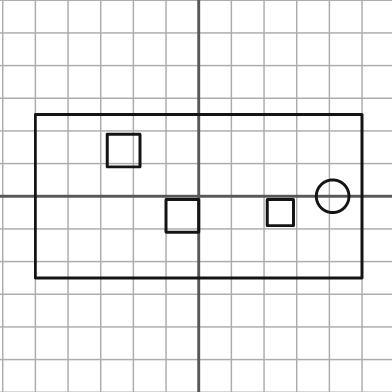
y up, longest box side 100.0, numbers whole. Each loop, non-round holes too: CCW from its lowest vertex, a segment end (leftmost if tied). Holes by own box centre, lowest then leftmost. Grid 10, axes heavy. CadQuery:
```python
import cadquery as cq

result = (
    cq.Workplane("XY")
    .moveTo(-50.0, -25.0)
    .lineTo(50.0, -25.0)
    .lineTo(50.0, 25.0)
    .lineTo(-50.0, 25.0)
    .close()
    .moveTo(-10.0, -11.0)
    .lineTo(0.0, -11.0)
    .lineTo(0.0, -1.0)
    .lineTo(-10.0, -1.0)
    .close()
    .moveTo(21.0, -9.0)
    .lineTo(29.0, -9.0)
    .lineTo(29.0, -1.0)
    .lineTo(21.0, -1.0)
    .close()
    .moveTo(41.0, 0.0)
    .circle(5.0)
    .moveTo(-28.0, 9.0)
    .lineTo(-18.0, 9.0)
    .lineTo(-18.0, 19.0)
    .lineTo(-28.0, 19.0)
    .close()
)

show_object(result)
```